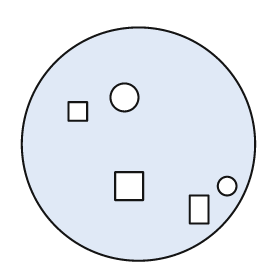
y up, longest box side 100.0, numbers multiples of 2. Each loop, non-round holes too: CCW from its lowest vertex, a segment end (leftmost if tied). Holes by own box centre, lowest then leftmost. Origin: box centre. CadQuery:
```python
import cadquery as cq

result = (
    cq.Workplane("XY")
    .moveTo(0.0, 0.0)
    .circle(50.0)
    .moveTo(22.0, -34.0)
    .lineTo(30.0, -34.0)
    .lineTo(30.0, -22.0)
    .lineTo(22.0, -22.0)
    .close()
    .moveTo(-10.0, -24.0)
    .lineTo(2.0, -24.0)
    .lineTo(2.0, -12.0)
    .lineTo(-10.0, -12.0)
    .close()
    .moveTo(38.0, -18.0)
    .circle(4.0)
    .moveTo(-30.0, 10.0)
    .lineTo(-22.0, 10.0)
    .lineTo(-22.0, 18.0)
    .lineTo(-30.0, 18.0)
    .close()
    .moveTo(-6.0, 20.0)
    .circle(6.0)
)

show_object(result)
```